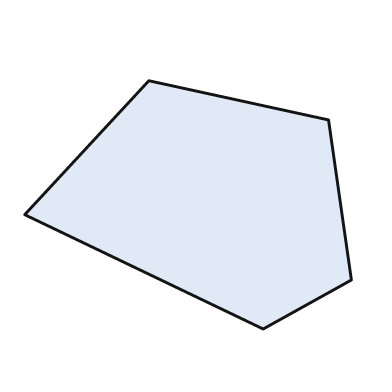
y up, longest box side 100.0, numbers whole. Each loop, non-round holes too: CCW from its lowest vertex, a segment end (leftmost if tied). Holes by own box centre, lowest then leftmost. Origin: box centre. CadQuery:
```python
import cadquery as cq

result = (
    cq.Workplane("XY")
    .moveTo(23.0, -38.0)
    .lineTo(50.0, -23.0)
    .lineTo(43.0, 26.0)
    .lineTo(-12.0, 38.0)
    .lineTo(-50.0, -3.0)
    .close()
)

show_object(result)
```